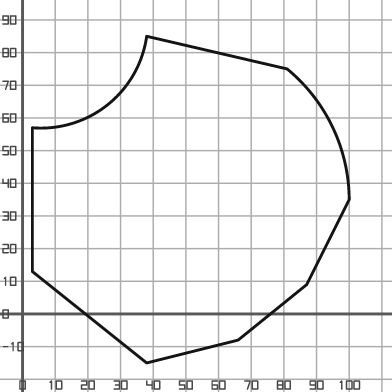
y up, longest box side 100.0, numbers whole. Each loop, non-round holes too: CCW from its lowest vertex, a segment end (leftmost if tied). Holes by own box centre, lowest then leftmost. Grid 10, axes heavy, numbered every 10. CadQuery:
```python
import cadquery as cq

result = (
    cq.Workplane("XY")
    .moveTo(38.0, -15.0)
    .lineTo(66.0, -8.0)
    .lineTo(87.0, 9.0)
    .lineTo(100.0, 35.0)
    .threePointArc((95.0, 57.0), (81.0, 75.0))
    .lineTo(38.0, 85.0)
    .threePointArc((26.0, 64.0), (3.0, 57.0))
    .lineTo(3.0, 13.0)
    .close()
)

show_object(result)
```